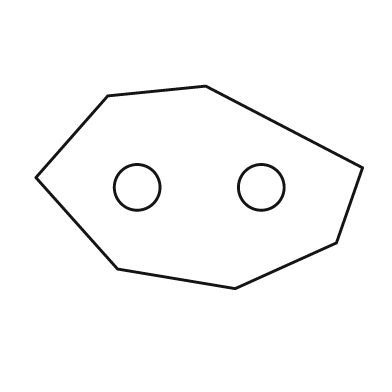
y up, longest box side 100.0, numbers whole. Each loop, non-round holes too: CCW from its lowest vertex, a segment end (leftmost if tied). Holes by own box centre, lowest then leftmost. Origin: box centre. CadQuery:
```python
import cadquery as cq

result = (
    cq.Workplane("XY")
    .moveTo(11.0, -31.0)
    .lineTo(42.0, -17.0)
    .lineTo(50.0, 6.0)
    .lineTo(2.0, 31.0)
    .lineTo(-28.0, 28.0)
    .lineTo(-50.0, 3.0)
    .lineTo(-25.0, -25.0)
    .close()
    .moveTo(-19.0, 0.0)
    .circle(7.0)
    .moveTo(19.0, 0.0)
    .circle(7.0)
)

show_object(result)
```